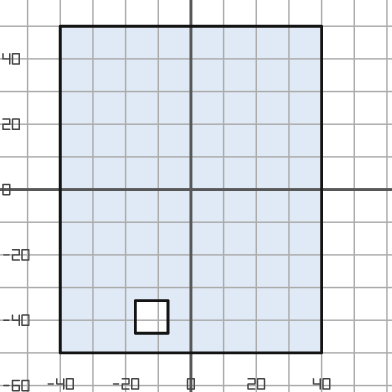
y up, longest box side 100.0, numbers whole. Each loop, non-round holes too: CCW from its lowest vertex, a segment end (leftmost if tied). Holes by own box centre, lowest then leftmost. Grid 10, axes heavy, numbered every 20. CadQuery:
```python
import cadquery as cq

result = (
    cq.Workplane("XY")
    .moveTo(-40.0, -50.0)
    .lineTo(40.0, -50.0)
    .lineTo(40.0, 50.0)
    .lineTo(-40.0, 50.0)
    .close()
    .moveTo(-17.0, -44.0)
    .lineTo(-7.0, -44.0)
    .lineTo(-7.0, -34.0)
    .lineTo(-17.0, -34.0)
    .close()
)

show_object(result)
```